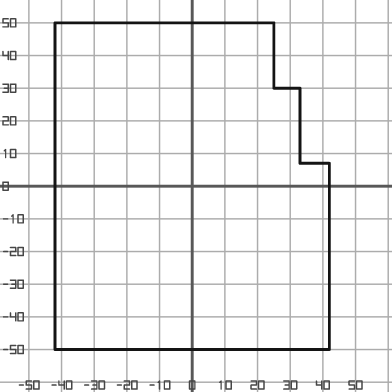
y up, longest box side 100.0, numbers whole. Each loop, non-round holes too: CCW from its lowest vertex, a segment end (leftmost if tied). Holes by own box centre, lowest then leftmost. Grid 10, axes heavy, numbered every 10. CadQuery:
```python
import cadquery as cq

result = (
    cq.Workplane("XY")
    .moveTo(-42.0, -50.0)
    .lineTo(42.0, -50.0)
    .lineTo(42.0, 7.0)
    .lineTo(33.0, 7.0)
    .lineTo(33.0, 30.0)
    .lineTo(25.0, 30.0)
    .lineTo(25.0, 50.0)
    .lineTo(-42.0, 50.0)
    .close()
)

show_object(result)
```